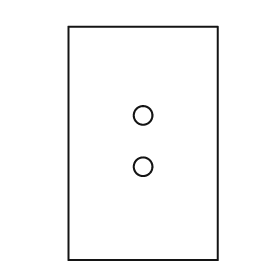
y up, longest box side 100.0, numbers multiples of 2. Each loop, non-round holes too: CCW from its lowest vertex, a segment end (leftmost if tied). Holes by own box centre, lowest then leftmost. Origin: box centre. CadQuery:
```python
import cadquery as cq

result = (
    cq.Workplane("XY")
    .moveTo(-32.0, -50.0)
    .lineTo(32.0, -50.0)
    .lineTo(32.0, 50.0)
    .lineTo(-32.0, 50.0)
    .close()
    .moveTo(0.0, -10.0)
    .circle(4.0)
    .moveTo(0.0, 12.0)
    .circle(4.0)
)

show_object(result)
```